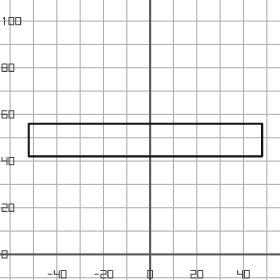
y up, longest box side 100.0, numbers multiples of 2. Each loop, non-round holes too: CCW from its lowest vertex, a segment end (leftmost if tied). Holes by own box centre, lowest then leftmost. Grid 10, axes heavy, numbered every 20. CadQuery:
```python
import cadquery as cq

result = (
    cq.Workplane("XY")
    .moveTo(-52.0, 42.0)
    .lineTo(48.0, 42.0)
    .lineTo(48.0, 56.0)
    .lineTo(-52.0, 56.0)
    .close()
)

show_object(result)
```